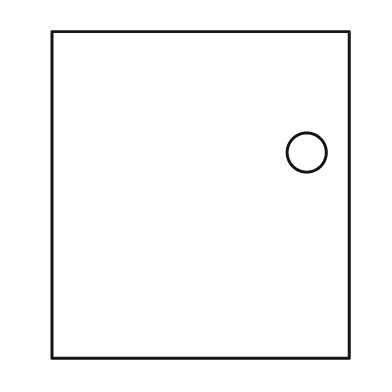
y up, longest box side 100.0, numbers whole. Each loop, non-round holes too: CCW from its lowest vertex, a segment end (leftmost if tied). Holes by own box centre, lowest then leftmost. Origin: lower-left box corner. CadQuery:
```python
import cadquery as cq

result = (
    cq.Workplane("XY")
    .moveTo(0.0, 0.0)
    .lineTo(91.0, 0.0)
    .lineTo(91.0, 100.0)
    .lineTo(0.0, 100.0)
    .close()
    .moveTo(78.0, 63.0)
    .circle(6.0)
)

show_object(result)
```